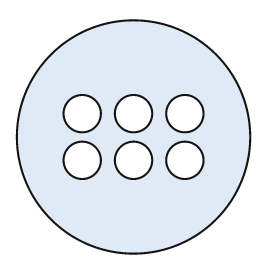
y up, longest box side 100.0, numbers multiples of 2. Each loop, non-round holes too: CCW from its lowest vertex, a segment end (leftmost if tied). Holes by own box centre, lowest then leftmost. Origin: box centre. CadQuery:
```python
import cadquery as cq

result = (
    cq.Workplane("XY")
    .moveTo(0.0, 0.0)
    .circle(50.0)
    .moveTo(-22.0, -10.0)
    .circle(8.0)
    .moveTo(0.0, -10.0)
    .circle(8.0)
    .moveTo(22.0, -10.0)
    .circle(8.0)
    .moveTo(-22.0, 10.0)
    .circle(8.0)
    .moveTo(0.0, 10.0)
    .circle(8.0)
    .moveTo(22.0, 10.0)
    .circle(8.0)
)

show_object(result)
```